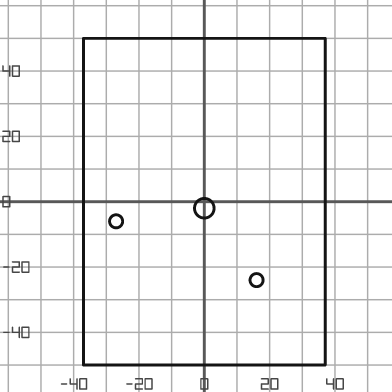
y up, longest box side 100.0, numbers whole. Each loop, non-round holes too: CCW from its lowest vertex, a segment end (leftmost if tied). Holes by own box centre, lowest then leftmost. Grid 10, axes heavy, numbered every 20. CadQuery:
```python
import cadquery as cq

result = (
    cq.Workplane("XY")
    .moveTo(-37.0, -50.0)
    .lineTo(37.0, -50.0)
    .lineTo(37.0, 50.0)
    .lineTo(-37.0, 50.0)
    .close()
    .moveTo(16.0, -24.0)
    .circle(2.0)
    .moveTo(-27.0, -6.0)
    .circle(2.0)
    .moveTo(0.0, -2.0)
    .circle(3.0)
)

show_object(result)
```